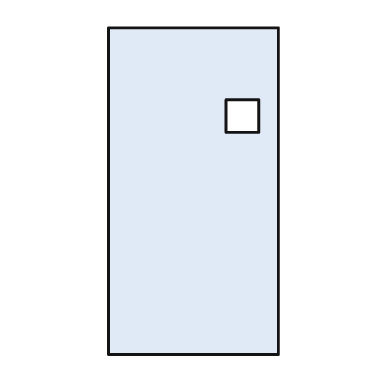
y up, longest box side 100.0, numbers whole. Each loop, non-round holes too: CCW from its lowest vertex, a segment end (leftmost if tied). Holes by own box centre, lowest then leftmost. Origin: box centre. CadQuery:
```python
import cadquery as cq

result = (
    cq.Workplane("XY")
    .moveTo(-26.0, -50.0)
    .lineTo(26.0, -50.0)
    .lineTo(26.0, 50.0)
    .lineTo(-26.0, 50.0)
    .close()
    .moveTo(10.0, 18.0)
    .lineTo(20.0, 18.0)
    .lineTo(20.0, 28.0)
    .lineTo(10.0, 28.0)
    .close()
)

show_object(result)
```